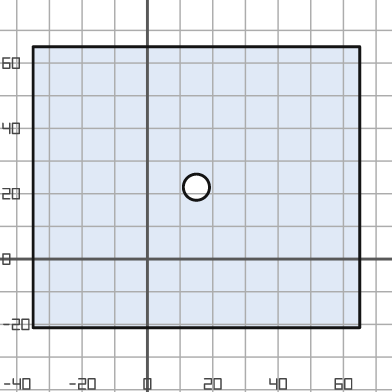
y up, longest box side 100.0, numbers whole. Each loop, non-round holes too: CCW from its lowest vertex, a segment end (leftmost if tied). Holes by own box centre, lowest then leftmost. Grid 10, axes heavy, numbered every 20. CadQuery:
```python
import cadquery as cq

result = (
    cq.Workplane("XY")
    .moveTo(-35.0, -21.0)
    .lineTo(65.0, -21.0)
    .lineTo(65.0, 65.0)
    .lineTo(-35.0, 65.0)
    .close()
    .moveTo(15.0, 22.0)
    .circle(4.0)
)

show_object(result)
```